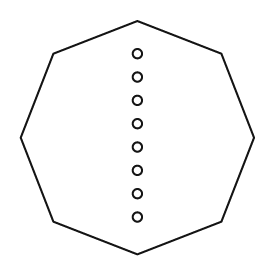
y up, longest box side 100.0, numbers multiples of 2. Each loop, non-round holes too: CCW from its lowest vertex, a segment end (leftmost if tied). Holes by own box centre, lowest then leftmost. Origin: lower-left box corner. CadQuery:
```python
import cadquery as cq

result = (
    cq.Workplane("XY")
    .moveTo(50.0, 0.0)
    .lineTo(86.0, 14.0)
    .lineTo(100.0, 50.0)
    .lineTo(86.0, 86.0)
    .lineTo(50.0, 100.0)
    .lineTo(14.0, 86.0)
    .lineTo(0.0, 50.0)
    .lineTo(14.0, 14.0)
    .close()
    .moveTo(50.0, 16.0)
    .circle(2.0)
    .moveTo(50.0, 26.0)
    .circle(2.0)
    .moveTo(50.0, 36.0)
    .circle(2.0)
    .moveTo(50.0, 46.0)
    .circle(2.0)
    .moveTo(50.0, 56.0)
    .circle(2.0)
    .moveTo(50.0, 66.0)
    .circle(2.0)
    .moveTo(50.0, 76.0)
    .circle(2.0)
    .moveTo(50.0, 86.0)
    .circle(2.0)
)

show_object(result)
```